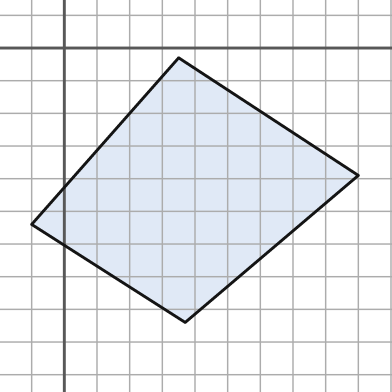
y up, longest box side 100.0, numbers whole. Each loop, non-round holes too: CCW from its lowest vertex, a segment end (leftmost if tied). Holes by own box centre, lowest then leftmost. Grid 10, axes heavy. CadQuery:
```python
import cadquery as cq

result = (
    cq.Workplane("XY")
    .moveTo(37.0, -84.0)
    .lineTo(90.0, -39.0)
    .lineTo(35.0, -3.0)
    .lineTo(-10.0, -54.0)
    .close()
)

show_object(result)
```